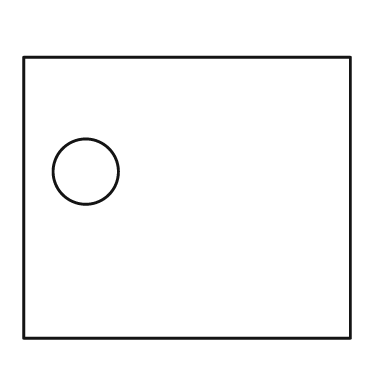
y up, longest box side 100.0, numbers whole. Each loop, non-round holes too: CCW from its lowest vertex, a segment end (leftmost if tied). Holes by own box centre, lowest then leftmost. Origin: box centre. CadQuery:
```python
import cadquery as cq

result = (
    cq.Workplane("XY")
    .moveTo(-50.0, -43.0)
    .lineTo(50.0, -43.0)
    .lineTo(50.0, 43.0)
    .lineTo(-50.0, 43.0)
    .close()
    .moveTo(-31.0, 8.0)
    .circle(10.0)
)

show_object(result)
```